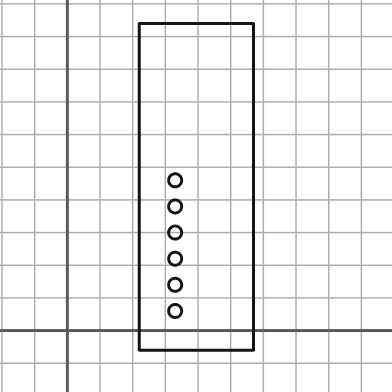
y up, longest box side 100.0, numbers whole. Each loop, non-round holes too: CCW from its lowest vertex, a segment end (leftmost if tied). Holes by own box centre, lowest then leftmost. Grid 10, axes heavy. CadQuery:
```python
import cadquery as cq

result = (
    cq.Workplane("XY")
    .moveTo(22.0, -6.0)
    .lineTo(57.0, -6.0)
    .lineTo(57.0, 94.0)
    .lineTo(22.0, 94.0)
    .close()
    .moveTo(33.0, 6.0)
    .circle(2.0)
    .moveTo(33.0, 14.0)
    .circle(2.0)
    .moveTo(33.0, 22.0)
    .circle(2.0)
    .moveTo(33.0, 30.0)
    .circle(2.0)
    .moveTo(33.0, 38.0)
    .circle(2.0)
    .moveTo(33.0, 46.0)
    .circle(2.0)
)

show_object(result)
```